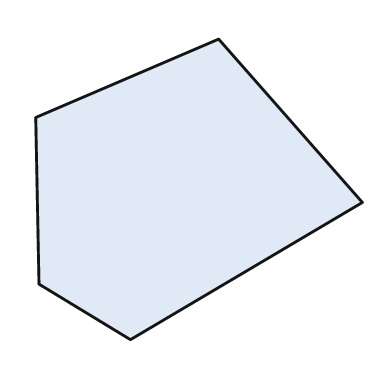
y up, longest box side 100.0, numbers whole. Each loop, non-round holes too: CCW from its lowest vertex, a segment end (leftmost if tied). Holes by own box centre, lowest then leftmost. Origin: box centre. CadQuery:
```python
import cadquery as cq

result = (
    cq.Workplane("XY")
    .moveTo(-21.0, -46.0)
    .lineTo(50.0, -4.0)
    .lineTo(6.0, 46.0)
    .lineTo(-50.0, 22.0)
    .lineTo(-49.0, -29.0)
    .close()
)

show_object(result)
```